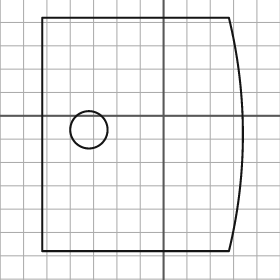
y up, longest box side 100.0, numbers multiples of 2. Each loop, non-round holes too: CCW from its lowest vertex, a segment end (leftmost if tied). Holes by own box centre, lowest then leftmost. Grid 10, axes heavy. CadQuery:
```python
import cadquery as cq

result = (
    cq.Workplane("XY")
    .moveTo(-52.0, -58.0)
    .lineTo(28.0, -58.0)
    .threePointArc((34.0, -8.0), (28.0, 42.0))
    .lineTo(-52.0, 42.0)
    .close()
    .moveTo(-32.0, -6.0)
    .circle(8.0)
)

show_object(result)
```